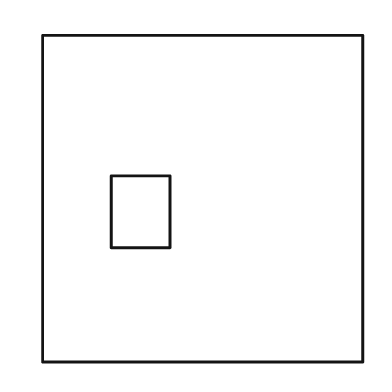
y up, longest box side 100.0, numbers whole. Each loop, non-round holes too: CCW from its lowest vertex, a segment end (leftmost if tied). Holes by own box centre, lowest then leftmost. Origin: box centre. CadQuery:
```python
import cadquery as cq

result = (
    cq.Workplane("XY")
    .moveTo(-49.0, -50.0)
    .lineTo(49.0, -50.0)
    .lineTo(49.0, 50.0)
    .lineTo(-49.0, 50.0)
    .close()
    .moveTo(-28.0, -15.0)
    .lineTo(-10.0, -15.0)
    .lineTo(-10.0, 7.0)
    .lineTo(-28.0, 7.0)
    .close()
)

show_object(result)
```